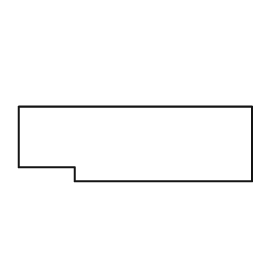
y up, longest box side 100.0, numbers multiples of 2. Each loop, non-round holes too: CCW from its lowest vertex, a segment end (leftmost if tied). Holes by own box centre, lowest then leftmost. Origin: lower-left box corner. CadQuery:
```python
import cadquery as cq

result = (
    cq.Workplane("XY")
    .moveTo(24.0, 0.0)
    .lineTo(100.0, 0.0)
    .lineTo(100.0, 32.0)
    .lineTo(0.0, 32.0)
    .lineTo(0.0, 6.0)
    .lineTo(24.0, 6.0)
    .close()
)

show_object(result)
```